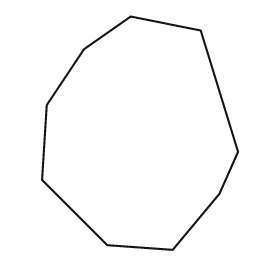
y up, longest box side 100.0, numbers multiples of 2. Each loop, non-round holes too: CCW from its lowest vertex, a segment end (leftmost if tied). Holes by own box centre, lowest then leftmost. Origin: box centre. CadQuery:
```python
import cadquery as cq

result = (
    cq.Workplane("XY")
    .moveTo(14.0, -50.0)
    .lineTo(34.0, -26.0)
    .lineTo(42.0, -8.0)
    .lineTo(26.0, 44.0)
    .lineTo(-4.0, 50.0)
    .lineTo(-24.0, 36.0)
    .lineTo(-40.0, 12.0)
    .lineTo(-42.0, -20.0)
    .lineTo(-14.0, -48.0)
    .close()
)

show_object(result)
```